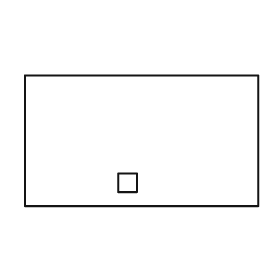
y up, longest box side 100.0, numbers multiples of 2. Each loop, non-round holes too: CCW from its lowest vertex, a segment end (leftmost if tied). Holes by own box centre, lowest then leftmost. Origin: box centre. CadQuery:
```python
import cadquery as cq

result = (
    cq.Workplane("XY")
    .moveTo(-50.0, -28.0)
    .lineTo(50.0, -28.0)
    .lineTo(50.0, 28.0)
    .lineTo(-50.0, 28.0)
    .close()
    .moveTo(-10.0, -22.0)
    .lineTo(-2.0, -22.0)
    .lineTo(-2.0, -14.0)
    .lineTo(-10.0, -14.0)
    .close()
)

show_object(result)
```